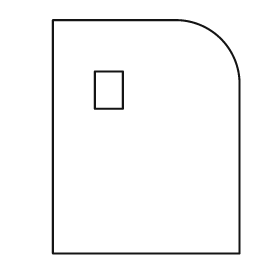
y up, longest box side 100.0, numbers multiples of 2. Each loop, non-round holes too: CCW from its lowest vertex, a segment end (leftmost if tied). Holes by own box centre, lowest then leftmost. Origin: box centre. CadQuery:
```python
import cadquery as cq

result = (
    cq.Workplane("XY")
    .moveTo(-40.0, -50.0)
    .lineTo(40.0, -50.0)
    .lineTo(40.0, 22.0)
    .threePointArc((32.0, 42.0), (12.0, 50.0))
    .lineTo(-40.0, 50.0)
    .close()
    .moveTo(-22.0, 12.0)
    .lineTo(-10.0, 12.0)
    .lineTo(-10.0, 28.0)
    .lineTo(-22.0, 28.0)
    .close()
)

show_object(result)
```